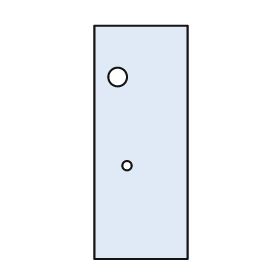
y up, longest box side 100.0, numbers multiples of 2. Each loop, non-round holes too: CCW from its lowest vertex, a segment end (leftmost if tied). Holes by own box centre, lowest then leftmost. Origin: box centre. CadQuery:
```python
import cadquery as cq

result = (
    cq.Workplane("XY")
    .moveTo(-20.0, -50.0)
    .lineTo(20.0, -50.0)
    .lineTo(20.0, 50.0)
    .lineTo(-20.0, 50.0)
    .close()
    .moveTo(-6.0, -10.0)
    .circle(2.0)
    .moveTo(-10.0, 28.0)
    .circle(4.0)
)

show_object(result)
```